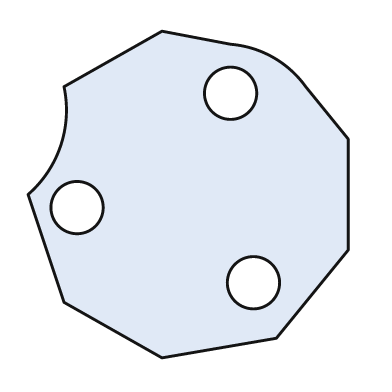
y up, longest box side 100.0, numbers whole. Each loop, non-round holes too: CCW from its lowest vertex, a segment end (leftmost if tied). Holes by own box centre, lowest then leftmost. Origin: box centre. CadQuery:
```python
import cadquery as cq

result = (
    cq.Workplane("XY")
    .moveTo(-8.0, -50.0)
    .lineTo(27.0, -44.0)
    .lineTo(49.0, -17.0)
    .lineTo(49.0, 17.0)
    .lineTo(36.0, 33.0)
    .threePointArc((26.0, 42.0), (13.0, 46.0))
    .lineTo(-8.0, 50.0)
    .lineTo(-38.0, 33.0)
    .threePointArc((-39.0, 15.0), (-49.0, 0.0))
    .lineTo(-38.0, -33.0)
    .close()
    .moveTo(20.0, -27.0)
    .circle(8.0)
    .moveTo(-34.0, -4.0)
    .circle(8.0)
    .moveTo(13.0, 31.0)
    .circle(8.0)
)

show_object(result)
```